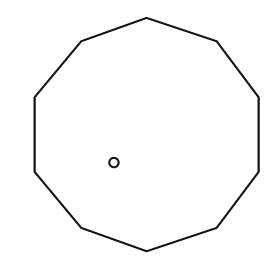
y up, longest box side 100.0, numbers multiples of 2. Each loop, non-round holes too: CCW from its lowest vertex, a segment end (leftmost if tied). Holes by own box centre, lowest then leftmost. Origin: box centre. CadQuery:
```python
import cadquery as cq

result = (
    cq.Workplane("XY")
    .moveTo(0.0, -50.0)
    .lineTo(30.0, -40.0)
    .lineTo(48.0, -16.0)
    .lineTo(48.0, 16.0)
    .lineTo(30.0, 40.0)
    .lineTo(0.0, 50.0)
    .lineTo(-28.0, 40.0)
    .lineTo(-48.0, 16.0)
    .lineTo(-48.0, -16.0)
    .lineTo(-28.0, -40.0)
    .close()
    .moveTo(-14.0, -12.0)
    .circle(2.0)
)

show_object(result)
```